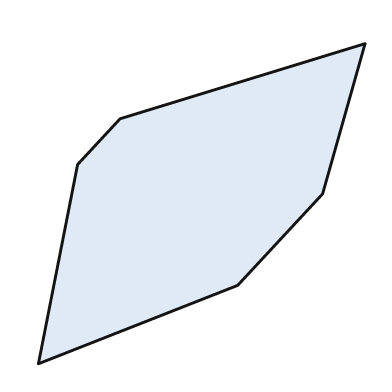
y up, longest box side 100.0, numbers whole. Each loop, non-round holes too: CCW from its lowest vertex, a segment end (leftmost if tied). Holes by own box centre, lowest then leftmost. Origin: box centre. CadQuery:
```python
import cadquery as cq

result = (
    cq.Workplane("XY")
    .moveTo(-50.0, -49.0)
    .lineTo(11.0, -25.0)
    .lineTo(37.0, 3.0)
    .lineTo(50.0, 49.0)
    .lineTo(-25.0, 26.0)
    .lineTo(-38.0, 12.0)
    .close()
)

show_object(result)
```